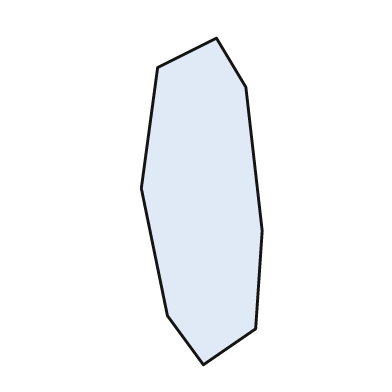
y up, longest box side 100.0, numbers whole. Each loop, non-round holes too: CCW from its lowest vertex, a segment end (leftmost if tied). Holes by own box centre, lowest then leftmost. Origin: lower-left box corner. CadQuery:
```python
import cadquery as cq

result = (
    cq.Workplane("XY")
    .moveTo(19.0, 0.0)
    .lineTo(35.0, 11.0)
    .lineTo(37.0, 41.0)
    .lineTo(32.0, 85.0)
    .lineTo(23.0, 100.0)
    .lineTo(5.0, 91.0)
    .lineTo(0.0, 54.0)
    .lineTo(8.0, 15.0)
    .close()
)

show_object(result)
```